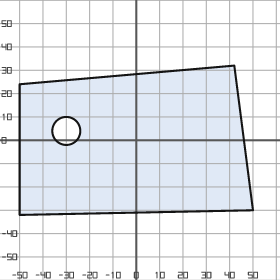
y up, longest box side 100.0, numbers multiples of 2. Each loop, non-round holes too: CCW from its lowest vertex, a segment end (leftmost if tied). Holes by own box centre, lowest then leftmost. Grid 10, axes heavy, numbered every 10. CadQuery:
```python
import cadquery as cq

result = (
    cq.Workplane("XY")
    .moveTo(-50.0, -32.0)
    .lineTo(50.0, -30.0)
    .lineTo(42.0, 32.0)
    .lineTo(-50.0, 24.0)
    .close()
    .moveTo(-30.0, 4.0)
    .circle(6.0)
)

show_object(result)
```